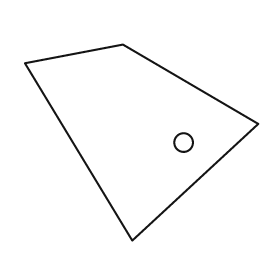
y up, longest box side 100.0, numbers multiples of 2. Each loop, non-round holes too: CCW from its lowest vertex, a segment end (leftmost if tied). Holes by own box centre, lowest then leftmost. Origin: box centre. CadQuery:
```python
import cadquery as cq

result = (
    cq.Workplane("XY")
    .moveTo(-4.0, -42.0)
    .lineTo(50.0, 8.0)
    .lineTo(-8.0, 42.0)
    .lineTo(-50.0, 34.0)
    .close()
    .moveTo(18.0, 0.0)
    .circle(4.0)
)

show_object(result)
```